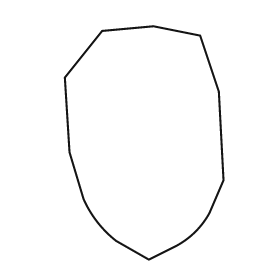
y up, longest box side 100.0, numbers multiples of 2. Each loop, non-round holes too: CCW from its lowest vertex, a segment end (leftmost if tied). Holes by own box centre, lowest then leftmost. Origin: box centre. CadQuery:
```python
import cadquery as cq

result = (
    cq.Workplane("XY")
    .moveTo(2.0, -50.0)
    .lineTo(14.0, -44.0)
    .threePointArc((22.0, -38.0), (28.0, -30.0))
    .lineTo(34.0, -16.0)
    .lineTo(32.0, 22.0)
    .lineTo(24.0, 46.0)
    .lineTo(4.0, 50.0)
    .lineTo(-18.0, 48.0)
    .lineTo(-34.0, 28.0)
    .lineTo(-32.0, -4.0)
    .lineTo(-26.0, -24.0)
    .threePointArc((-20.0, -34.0), (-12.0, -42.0))
    .close()
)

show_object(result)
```